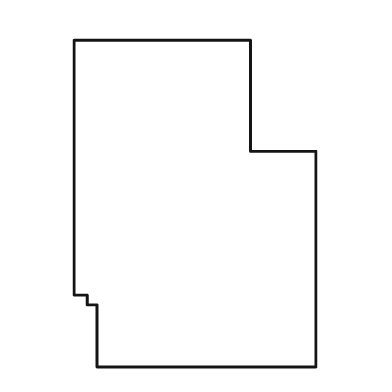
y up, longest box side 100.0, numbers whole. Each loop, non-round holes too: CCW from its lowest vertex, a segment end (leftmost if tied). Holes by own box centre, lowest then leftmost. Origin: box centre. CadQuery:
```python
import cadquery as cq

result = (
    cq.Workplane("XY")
    .moveTo(-30.0, -50.0)
    .lineTo(37.0, -50.0)
    .lineTo(37.0, 16.0)
    .lineTo(17.0, 16.0)
    .lineTo(17.0, 50.0)
    .lineTo(-37.0, 50.0)
    .lineTo(-37.0, -28.0)
    .lineTo(-33.0, -28.0)
    .lineTo(-33.0, -31.0)
    .lineTo(-30.0, -31.0)
    .close()
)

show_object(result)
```